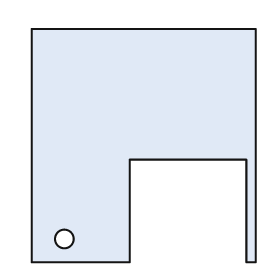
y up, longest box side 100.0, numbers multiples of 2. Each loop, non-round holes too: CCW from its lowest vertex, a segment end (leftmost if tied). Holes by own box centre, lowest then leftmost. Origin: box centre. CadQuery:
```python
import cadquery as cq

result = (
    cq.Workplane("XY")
    .moveTo(-48.0, -50.0)
    .lineTo(-6.0, -50.0)
    .lineTo(-6.0, -6.0)
    .lineTo(44.0, -6.0)
    .lineTo(44.0, -50.0)
    .lineTo(48.0, -50.0)
    .lineTo(48.0, 50.0)
    .lineTo(-48.0, 50.0)
    .close()
    .moveTo(-34.0, -40.0)
    .circle(4.0)
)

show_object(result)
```